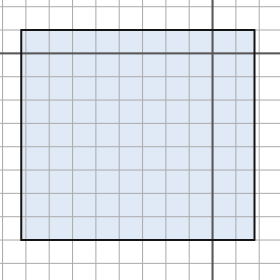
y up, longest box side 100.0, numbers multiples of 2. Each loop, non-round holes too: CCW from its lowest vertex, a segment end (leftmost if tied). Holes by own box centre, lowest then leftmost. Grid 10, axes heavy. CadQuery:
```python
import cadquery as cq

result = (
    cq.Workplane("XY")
    .moveTo(-82.0, -80.0)
    .lineTo(18.0, -80.0)
    .lineTo(18.0, 10.0)
    .lineTo(-82.0, 10.0)
    .close()
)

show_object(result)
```